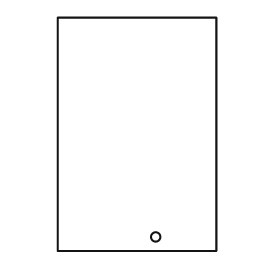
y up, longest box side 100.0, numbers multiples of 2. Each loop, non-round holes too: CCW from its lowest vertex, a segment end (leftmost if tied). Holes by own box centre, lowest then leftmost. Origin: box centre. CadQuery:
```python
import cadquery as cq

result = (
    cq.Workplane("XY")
    .moveTo(-34.0, -50.0)
    .lineTo(34.0, -50.0)
    .lineTo(34.0, 50.0)
    .lineTo(-34.0, 50.0)
    .close()
    .moveTo(8.0, -44.0)
    .circle(2.0)
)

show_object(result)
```